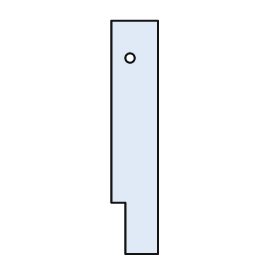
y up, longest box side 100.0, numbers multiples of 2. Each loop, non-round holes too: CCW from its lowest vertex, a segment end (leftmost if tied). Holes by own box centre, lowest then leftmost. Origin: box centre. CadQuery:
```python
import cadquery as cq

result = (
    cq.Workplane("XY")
    .moveTo(-4.0, -50.0)
    .lineTo(10.0, -50.0)
    .lineTo(10.0, 50.0)
    .lineTo(-10.0, 50.0)
    .lineTo(-10.0, -28.0)
    .lineTo(-4.0, -28.0)
    .close()
    .moveTo(-2.0, 34.0)
    .circle(2.0)
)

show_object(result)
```